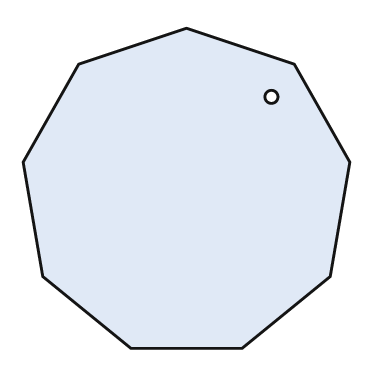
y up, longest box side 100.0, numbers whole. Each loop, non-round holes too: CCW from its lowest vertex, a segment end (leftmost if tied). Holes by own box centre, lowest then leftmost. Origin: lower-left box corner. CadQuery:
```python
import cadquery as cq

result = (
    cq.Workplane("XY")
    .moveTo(33.0, 0.0)
    .lineTo(67.0, 0.0)
    .lineTo(94.0, 22.0)
    .lineTo(100.0, 57.0)
    .lineTo(83.0, 87.0)
    .lineTo(50.0, 98.0)
    .lineTo(17.0, 87.0)
    .lineTo(0.0, 57.0)
    .lineTo(6.0, 22.0)
    .close()
    .moveTo(76.0, 77.0)
    .circle(2.0)
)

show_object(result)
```